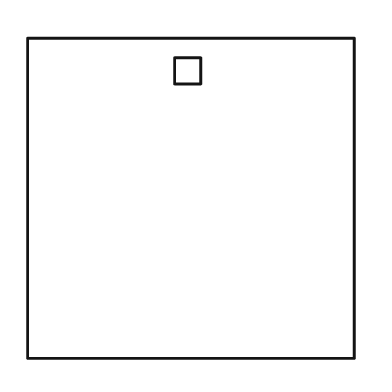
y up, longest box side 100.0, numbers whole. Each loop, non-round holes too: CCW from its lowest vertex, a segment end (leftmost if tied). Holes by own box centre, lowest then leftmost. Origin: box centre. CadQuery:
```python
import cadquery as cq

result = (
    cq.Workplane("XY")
    .moveTo(-50.0, -49.0)
    .lineTo(50.0, -49.0)
    .lineTo(50.0, 49.0)
    .lineTo(-50.0, 49.0)
    .close()
    .moveTo(-5.0, 35.0)
    .lineTo(3.0, 35.0)
    .lineTo(3.0, 43.0)
    .lineTo(-5.0, 43.0)
    .close()
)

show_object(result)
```